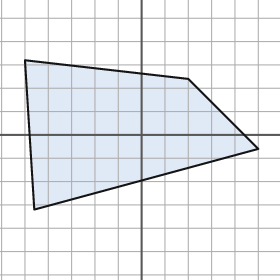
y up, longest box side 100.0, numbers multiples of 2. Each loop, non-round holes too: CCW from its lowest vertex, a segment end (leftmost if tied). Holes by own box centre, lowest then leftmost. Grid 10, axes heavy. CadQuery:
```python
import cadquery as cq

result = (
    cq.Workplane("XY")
    .moveTo(-46.0, -32.0)
    .lineTo(50.0, -6.0)
    .lineTo(20.0, 24.0)
    .lineTo(-50.0, 32.0)
    .close()
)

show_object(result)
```